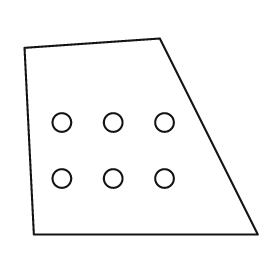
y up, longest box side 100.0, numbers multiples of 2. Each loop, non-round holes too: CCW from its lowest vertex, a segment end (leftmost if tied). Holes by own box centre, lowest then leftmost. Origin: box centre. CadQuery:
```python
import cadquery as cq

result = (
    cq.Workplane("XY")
    .moveTo(-46.0, -42.0)
    .lineTo(50.0, -42.0)
    .lineTo(8.0, 42.0)
    .lineTo(-50.0, 38.0)
    .close()
    .moveTo(-34.0, -18.0)
    .circle(4.0)
    .moveTo(-12.0, -18.0)
    .circle(4.0)
    .moveTo(10.0, -18.0)
    .circle(4.0)
    .moveTo(-34.0, 6.0)
    .circle(4.0)
    .moveTo(-12.0, 6.0)
    .circle(4.0)
    .moveTo(10.0, 6.0)
    .circle(4.0)
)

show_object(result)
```